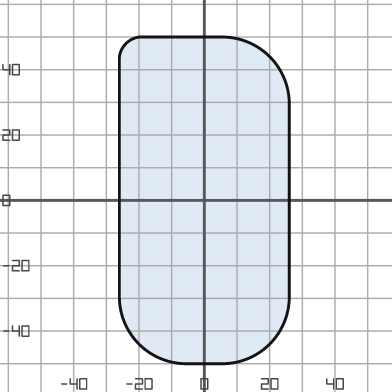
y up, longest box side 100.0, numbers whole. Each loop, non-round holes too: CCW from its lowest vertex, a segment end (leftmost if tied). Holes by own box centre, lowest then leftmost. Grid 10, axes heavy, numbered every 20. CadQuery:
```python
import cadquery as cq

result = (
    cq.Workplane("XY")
    .moveTo(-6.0, -50.0)
    .lineTo(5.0, -50.0)
    .threePointArc((20.0, -44.0), (26.0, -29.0))
    .lineTo(26.0, 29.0)
    .threePointArc((20.0, 44.0), (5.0, 50.0))
    .lineTo(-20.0, 50.0)
    .threePointArc((-24.0, 48.0), (-26.0, 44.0))
    .lineTo(-26.0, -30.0)
    .threePointArc((-20.0, -44.0), (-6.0, -50.0))
    .close()
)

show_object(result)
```